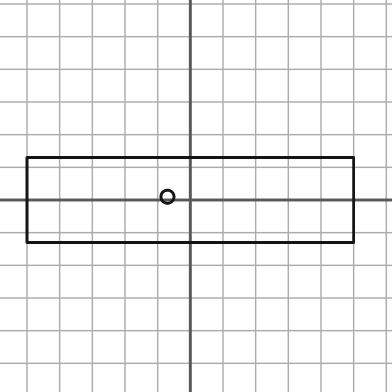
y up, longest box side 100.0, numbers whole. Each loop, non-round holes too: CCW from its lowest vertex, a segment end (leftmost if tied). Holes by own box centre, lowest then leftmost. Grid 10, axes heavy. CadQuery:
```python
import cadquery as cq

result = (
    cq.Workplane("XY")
    .moveTo(-50.0, -13.0)
    .lineTo(50.0, -13.0)
    .lineTo(50.0, 13.0)
    .lineTo(-50.0, 13.0)
    .close()
    .moveTo(-7.0, 1.0)
    .circle(2.0)
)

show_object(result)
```